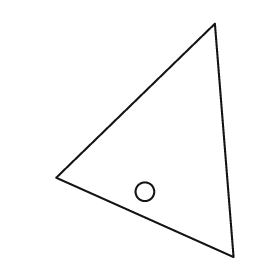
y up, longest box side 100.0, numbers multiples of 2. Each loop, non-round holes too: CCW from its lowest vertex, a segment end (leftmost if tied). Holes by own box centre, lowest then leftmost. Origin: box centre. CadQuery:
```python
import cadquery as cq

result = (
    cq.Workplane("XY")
    .moveTo(38.0, -50.0)
    .lineTo(30.0, 50.0)
    .lineTo(-38.0, -16.0)
    .close()
    .moveTo(0.0, -22.0)
    .circle(4.0)
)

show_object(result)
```